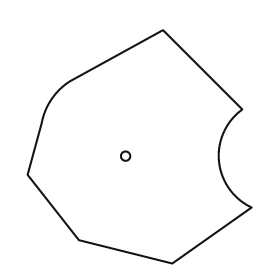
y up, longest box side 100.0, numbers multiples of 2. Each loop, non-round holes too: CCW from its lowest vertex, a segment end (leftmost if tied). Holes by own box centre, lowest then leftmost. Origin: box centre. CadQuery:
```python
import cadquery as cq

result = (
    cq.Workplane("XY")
    .moveTo(14.0, -50.0)
    .lineTo(48.0, -26.0)
    .threePointArc((34.0, -6.0), (44.0, 16.0))
    .lineTo(10.0, 50.0)
    .lineTo(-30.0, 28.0)
    .threePointArc((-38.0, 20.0), (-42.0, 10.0))
    .lineTo(-48.0, -12.0)
    .lineTo(-26.0, -40.0)
    .close()
    .moveTo(-6.0, -4.0)
    .circle(2.0)
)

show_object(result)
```